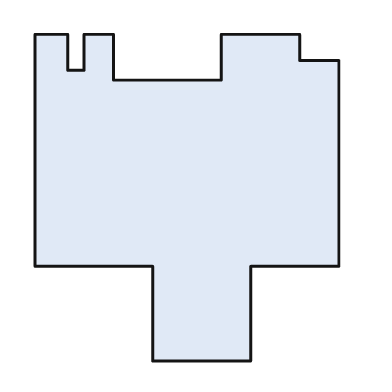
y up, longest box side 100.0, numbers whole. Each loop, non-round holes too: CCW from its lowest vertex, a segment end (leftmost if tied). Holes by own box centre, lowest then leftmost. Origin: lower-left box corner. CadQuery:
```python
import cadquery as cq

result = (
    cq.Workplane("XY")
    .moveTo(36.0, 0.0)
    .lineTo(66.0, 0.0)
    .lineTo(66.0, 29.0)
    .lineTo(93.0, 29.0)
    .lineTo(93.0, 92.0)
    .lineTo(81.0, 92.0)
    .lineTo(81.0, 100.0)
    .lineTo(57.0, 100.0)
    .lineTo(57.0, 86.0)
    .lineTo(24.0, 86.0)
    .lineTo(24.0, 100.0)
    .lineTo(15.0, 100.0)
    .lineTo(15.0, 89.0)
    .lineTo(10.0, 89.0)
    .lineTo(10.0, 100.0)
    .lineTo(0.0, 100.0)
    .lineTo(0.0, 29.0)
    .lineTo(36.0, 29.0)
    .close()
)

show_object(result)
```